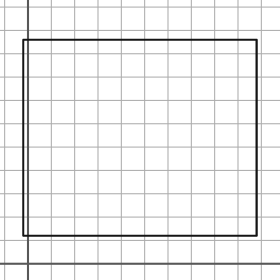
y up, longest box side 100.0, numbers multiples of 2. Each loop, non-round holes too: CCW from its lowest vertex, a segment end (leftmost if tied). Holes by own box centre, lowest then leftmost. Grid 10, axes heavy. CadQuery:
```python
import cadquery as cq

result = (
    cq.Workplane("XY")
    .moveTo(-2.0, 12.0)
    .lineTo(98.0, 12.0)
    .lineTo(98.0, 96.0)
    .lineTo(-2.0, 96.0)
    .close()
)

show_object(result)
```